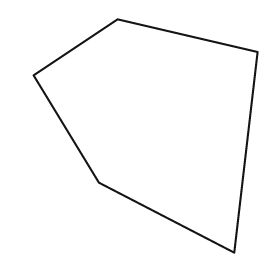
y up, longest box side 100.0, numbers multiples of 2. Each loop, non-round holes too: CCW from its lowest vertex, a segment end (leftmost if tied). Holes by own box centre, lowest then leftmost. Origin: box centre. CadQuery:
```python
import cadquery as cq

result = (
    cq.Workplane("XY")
    .moveTo(38.0, -50.0)
    .lineTo(48.0, 36.0)
    .lineTo(-12.0, 50.0)
    .lineTo(-48.0, 26.0)
    .lineTo(-20.0, -20.0)
    .close()
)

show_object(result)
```